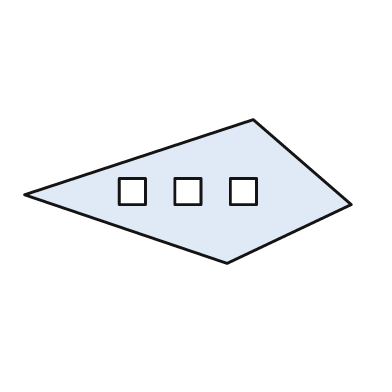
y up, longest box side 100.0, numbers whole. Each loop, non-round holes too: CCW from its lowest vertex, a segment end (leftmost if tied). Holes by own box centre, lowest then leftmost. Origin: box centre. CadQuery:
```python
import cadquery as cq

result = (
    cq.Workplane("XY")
    .moveTo(12.0, -22.0)
    .lineTo(50.0, -4.0)
    .lineTo(20.0, 22.0)
    .lineTo(-50.0, -1.0)
    .close()
    .moveTo(-21.0, -4.0)
    .lineTo(-13.0, -4.0)
    .lineTo(-13.0, 4.0)
    .lineTo(-21.0, 4.0)
    .close()
    .moveTo(-4.0, -4.0)
    .lineTo(4.0, -4.0)
    .lineTo(4.0, 4.0)
    .lineTo(-4.0, 4.0)
    .close()
    .moveTo(13.0, -4.0)
    .lineTo(21.0, -4.0)
    .lineTo(21.0, 4.0)
    .lineTo(13.0, 4.0)
    .close()
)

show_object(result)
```